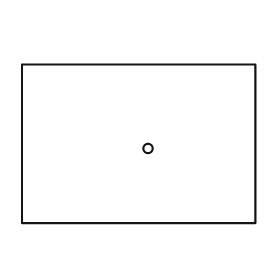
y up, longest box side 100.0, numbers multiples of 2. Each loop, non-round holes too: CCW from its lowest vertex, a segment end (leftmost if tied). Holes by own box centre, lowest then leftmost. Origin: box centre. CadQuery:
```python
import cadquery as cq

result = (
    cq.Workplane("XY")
    .moveTo(-50.0, -34.0)
    .lineTo(50.0, -34.0)
    .lineTo(50.0, 34.0)
    .lineTo(-50.0, 34.0)
    .close()
    .moveTo(4.0, -2.0)
    .circle(2.0)
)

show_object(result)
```